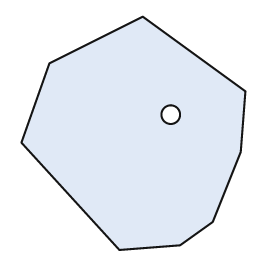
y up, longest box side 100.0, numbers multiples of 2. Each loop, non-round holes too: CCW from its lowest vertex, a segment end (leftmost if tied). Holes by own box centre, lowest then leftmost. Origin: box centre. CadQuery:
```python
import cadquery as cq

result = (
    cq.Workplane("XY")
    .moveTo(-6.0, -50.0)
    .lineTo(20.0, -48.0)
    .lineTo(34.0, -38.0)
    .lineTo(46.0, -8.0)
    .lineTo(48.0, 18.0)
    .lineTo(4.0, 50.0)
    .lineTo(-36.0, 30.0)
    .lineTo(-48.0, -4.0)
    .close()
    .moveTo(16.0, 8.0)
    .circle(4.0)
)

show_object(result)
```